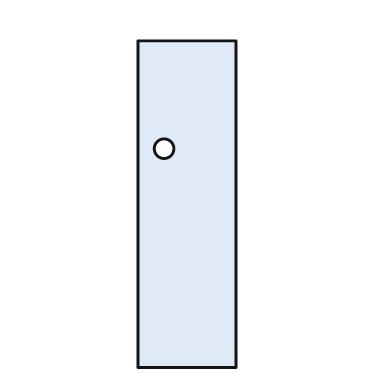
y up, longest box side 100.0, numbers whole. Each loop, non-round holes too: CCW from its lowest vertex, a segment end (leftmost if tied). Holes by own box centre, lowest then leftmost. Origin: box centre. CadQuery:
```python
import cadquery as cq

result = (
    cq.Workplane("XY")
    .moveTo(-15.0, -50.0)
    .lineTo(15.0, -50.0)
    .lineTo(15.0, 50.0)
    .lineTo(-15.0, 50.0)
    .close()
    .moveTo(-7.0, 17.0)
    .circle(3.0)
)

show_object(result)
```